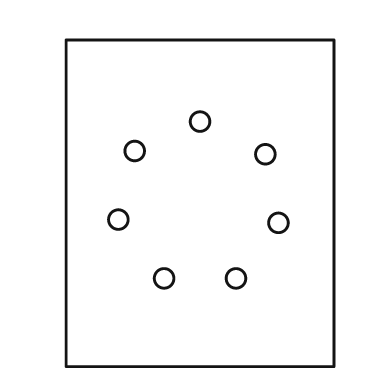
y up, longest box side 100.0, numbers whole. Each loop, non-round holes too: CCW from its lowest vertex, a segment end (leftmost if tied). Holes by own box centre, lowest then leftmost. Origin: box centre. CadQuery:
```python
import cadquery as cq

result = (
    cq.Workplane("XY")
    .moveTo(-41.0, -50.0)
    .lineTo(41.0, -50.0)
    .lineTo(41.0, 50.0)
    .lineTo(-41.0, 50.0)
    .close()
    .moveTo(-11.0, -23.0)
    .circle(3.0)
    .moveTo(11.0, -23.0)
    .circle(3.0)
    .moveTo(24.0, -6.0)
    .circle(3.0)
    .moveTo(-25.0, -5.0)
    .circle(3.0)
    .moveTo(20.0, 15.0)
    .circle(3.0)
    .moveTo(-20.0, 16.0)
    .circle(3.0)
    .moveTo(0.0, 25.0)
    .circle(3.0)
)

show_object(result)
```